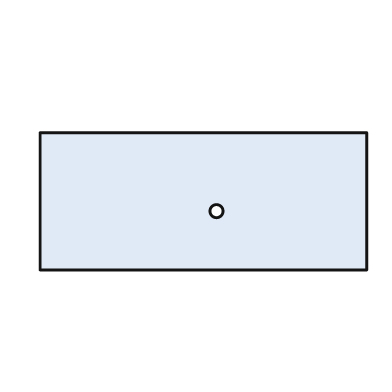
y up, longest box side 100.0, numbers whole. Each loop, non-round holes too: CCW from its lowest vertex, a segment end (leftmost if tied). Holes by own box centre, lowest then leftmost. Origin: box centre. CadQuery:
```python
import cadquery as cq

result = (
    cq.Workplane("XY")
    .moveTo(-50.0, -21.0)
    .lineTo(50.0, -21.0)
    .lineTo(50.0, 21.0)
    .lineTo(-50.0, 21.0)
    .close()
    .moveTo(4.0, -3.0)
    .circle(2.0)
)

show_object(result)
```